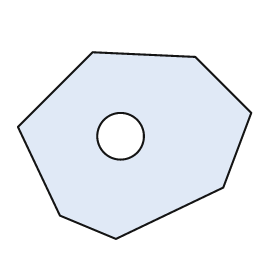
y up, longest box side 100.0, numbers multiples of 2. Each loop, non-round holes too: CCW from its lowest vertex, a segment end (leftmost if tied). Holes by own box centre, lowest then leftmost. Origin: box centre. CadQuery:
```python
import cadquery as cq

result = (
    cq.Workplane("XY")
    .moveTo(-8.0, -40.0)
    .lineTo(38.0, -18.0)
    .lineTo(50.0, 14.0)
    .lineTo(26.0, 38.0)
    .lineTo(-18.0, 40.0)
    .lineTo(-50.0, 8.0)
    .lineTo(-32.0, -30.0)
    .close()
    .moveTo(-6.0, 4.0)
    .circle(10.0)
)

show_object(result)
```